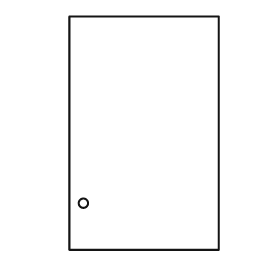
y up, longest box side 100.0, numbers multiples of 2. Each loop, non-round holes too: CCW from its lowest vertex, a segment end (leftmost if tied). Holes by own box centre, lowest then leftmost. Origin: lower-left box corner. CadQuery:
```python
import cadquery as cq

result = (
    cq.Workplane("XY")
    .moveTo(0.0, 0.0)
    .lineTo(64.0, 0.0)
    .lineTo(64.0, 100.0)
    .lineTo(0.0, 100.0)
    .close()
    .moveTo(6.0, 20.0)
    .circle(2.0)
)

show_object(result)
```